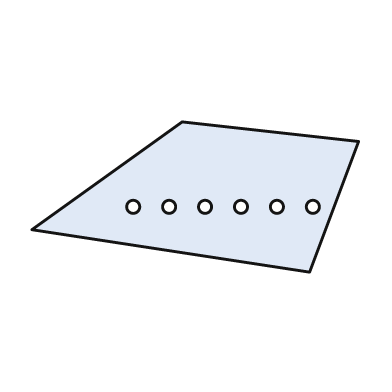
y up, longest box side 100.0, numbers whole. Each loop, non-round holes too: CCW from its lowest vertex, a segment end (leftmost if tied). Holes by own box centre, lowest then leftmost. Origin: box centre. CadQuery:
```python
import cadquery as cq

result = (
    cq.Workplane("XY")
    .moveTo(35.0, -23.0)
    .lineTo(50.0, 17.0)
    .lineTo(-4.0, 23.0)
    .lineTo(-50.0, -10.0)
    .close()
    .moveTo(-19.0, -3.0)
    .circle(2.0)
    .moveTo(-8.0, -3.0)
    .circle(2.0)
    .moveTo(3.0, -3.0)
    .circle(2.0)
    .moveTo(14.0, -3.0)
    .circle(2.0)
    .moveTo(25.0, -3.0)
    .circle(2.0)
    .moveTo(36.0, -3.0)
    .circle(2.0)
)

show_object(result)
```